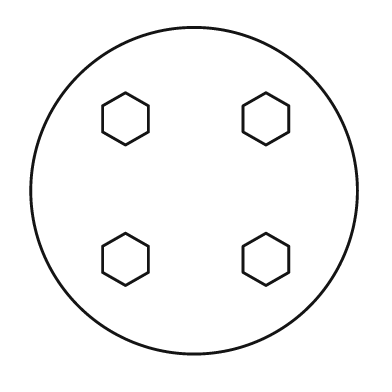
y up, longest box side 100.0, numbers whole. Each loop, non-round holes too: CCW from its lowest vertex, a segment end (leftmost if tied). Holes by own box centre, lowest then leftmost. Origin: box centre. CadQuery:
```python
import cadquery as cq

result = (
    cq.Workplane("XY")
    .moveTo(0.0, 0.0)
    .circle(50.0)
    .moveTo(-21.0, -29.0)
    .lineTo(-14.0, -25.0)
    .lineTo(-14.0, -17.0)
    .lineTo(-21.0, -13.0)
    .lineTo(-28.0, -17.0)
    .lineTo(-28.0, -25.0)
    .close()
    .moveTo(22.0, -29.0)
    .lineTo(29.0, -25.0)
    .lineTo(29.0, -17.0)
    .lineTo(22.0, -13.0)
    .lineTo(15.0, -17.0)
    .lineTo(15.0, -25.0)
    .close()
    .moveTo(-21.0, 14.0)
    .lineTo(-14.0, 18.0)
    .lineTo(-14.0, 26.0)
    .lineTo(-21.0, 30.0)
    .lineTo(-28.0, 26.0)
    .lineTo(-28.0, 18.0)
    .close()
    .moveTo(22.0, 14.0)
    .lineTo(29.0, 18.0)
    .lineTo(29.0, 26.0)
    .lineTo(22.0, 30.0)
    .lineTo(15.0, 26.0)
    .lineTo(15.0, 18.0)
    .close()
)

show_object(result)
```